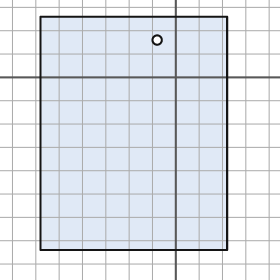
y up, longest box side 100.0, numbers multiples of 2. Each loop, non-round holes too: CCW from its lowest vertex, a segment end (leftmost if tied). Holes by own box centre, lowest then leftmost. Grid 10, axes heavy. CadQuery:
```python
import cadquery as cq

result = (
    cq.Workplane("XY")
    .moveTo(-58.0, -74.0)
    .lineTo(22.0, -74.0)
    .lineTo(22.0, 26.0)
    .lineTo(-58.0, 26.0)
    .close()
    .moveTo(-8.0, 16.0)
    .circle(2.0)
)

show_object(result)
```